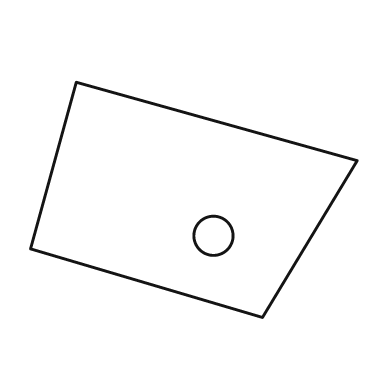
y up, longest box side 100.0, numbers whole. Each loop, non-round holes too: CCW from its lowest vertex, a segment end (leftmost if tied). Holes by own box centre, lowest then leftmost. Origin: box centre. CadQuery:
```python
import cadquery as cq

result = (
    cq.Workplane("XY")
    .moveTo(21.0, -36.0)
    .lineTo(50.0, 12.0)
    .lineTo(-36.0, 36.0)
    .lineTo(-50.0, -15.0)
    .close()
    .moveTo(6.0, -11.0)
    .circle(6.0)
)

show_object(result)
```